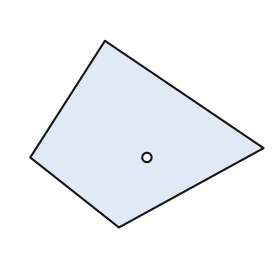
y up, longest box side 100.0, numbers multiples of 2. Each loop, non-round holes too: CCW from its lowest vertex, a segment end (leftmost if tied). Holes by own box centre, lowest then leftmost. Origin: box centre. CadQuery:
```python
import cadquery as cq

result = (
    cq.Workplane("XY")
    .moveTo(-12.0, -40.0)
    .lineTo(50.0, -6.0)
    .lineTo(-18.0, 40.0)
    .lineTo(-50.0, -10.0)
    .close()
    .moveTo(0.0, -10.0)
    .circle(2.0)
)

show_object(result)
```